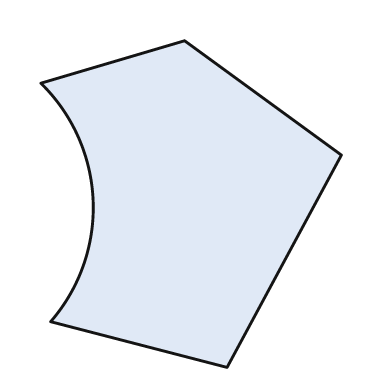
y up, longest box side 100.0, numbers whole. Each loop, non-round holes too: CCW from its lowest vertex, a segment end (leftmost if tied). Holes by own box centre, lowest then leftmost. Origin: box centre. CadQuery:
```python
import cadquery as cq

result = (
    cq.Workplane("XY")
    .moveTo(11.0, -50.0)
    .lineTo(46.0, 15.0)
    .lineTo(-2.0, 50.0)
    .lineTo(-46.0, 37.0)
    .threePointArc((-30.0, 1.0), (-43.0, -36.0))
    .close()
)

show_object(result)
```